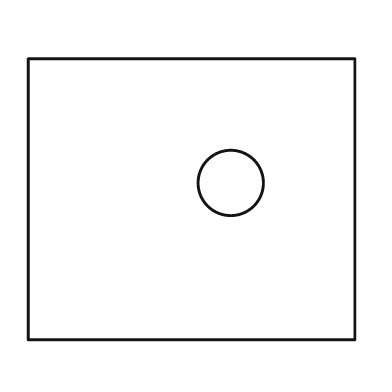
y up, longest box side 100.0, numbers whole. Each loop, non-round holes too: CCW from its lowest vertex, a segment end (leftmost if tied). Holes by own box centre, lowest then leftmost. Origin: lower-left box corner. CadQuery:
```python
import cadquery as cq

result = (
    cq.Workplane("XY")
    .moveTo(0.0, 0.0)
    .lineTo(100.0, 0.0)
    .lineTo(100.0, 86.0)
    .lineTo(0.0, 86.0)
    .close()
    .moveTo(62.0, 48.0)
    .circle(10.0)
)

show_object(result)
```